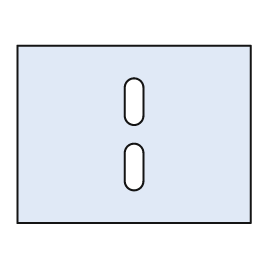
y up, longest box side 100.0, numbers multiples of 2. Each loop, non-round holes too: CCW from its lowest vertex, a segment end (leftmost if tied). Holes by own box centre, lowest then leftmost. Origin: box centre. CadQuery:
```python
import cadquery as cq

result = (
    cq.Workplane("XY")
    .moveTo(-50.0, -38.0)
    .lineTo(50.0, -38.0)
    .lineTo(50.0, 38.0)
    .lineTo(-50.0, 38.0)
    .close()
    .moveTo(-4.0, -20.0)
    .threePointArc((0.0, -24.0), (4.0, -20.0))
    .lineTo(4.0, -8.0)
    .threePointArc((0.0, -4.0), (-4.0, -8.0))
    .close()
    .moveTo(-4.0, 8.0)
    .threePointArc((0.0, 4.0), (4.0, 8.0))
    .lineTo(4.0, 20.0)
    .threePointArc((0.0, 24.0), (-4.0, 20.0))
    .close()
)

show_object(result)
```